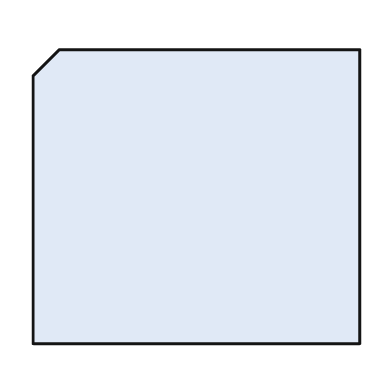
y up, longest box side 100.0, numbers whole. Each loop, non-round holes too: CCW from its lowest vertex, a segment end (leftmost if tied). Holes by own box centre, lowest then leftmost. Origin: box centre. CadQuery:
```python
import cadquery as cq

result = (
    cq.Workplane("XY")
    .moveTo(-50.0, -45.0)
    .lineTo(50.0, -45.0)
    .lineTo(50.0, 45.0)
    .lineTo(-42.0, 45.0)
    .lineTo(-50.0, 37.0)
    .close()
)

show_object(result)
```